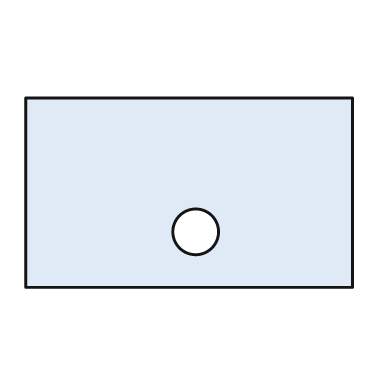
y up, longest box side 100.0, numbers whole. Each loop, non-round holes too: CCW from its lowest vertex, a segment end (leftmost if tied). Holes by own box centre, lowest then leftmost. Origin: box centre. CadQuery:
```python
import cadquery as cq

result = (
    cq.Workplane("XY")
    .moveTo(-50.0, -29.0)
    .lineTo(50.0, -29.0)
    .lineTo(50.0, 29.0)
    .lineTo(-50.0, 29.0)
    .close()
    .moveTo(2.0, -12.0)
    .circle(7.0)
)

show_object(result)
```